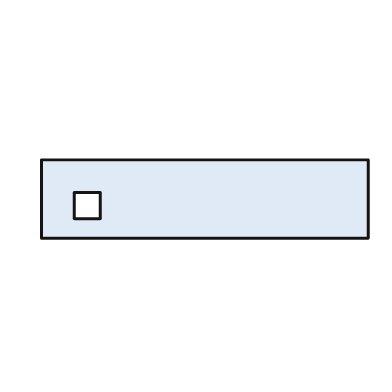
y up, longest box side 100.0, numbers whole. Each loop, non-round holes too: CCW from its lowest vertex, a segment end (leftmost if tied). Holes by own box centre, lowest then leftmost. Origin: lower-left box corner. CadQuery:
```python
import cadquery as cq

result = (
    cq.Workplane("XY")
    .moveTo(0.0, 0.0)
    .lineTo(100.0, 0.0)
    .lineTo(100.0, 24.0)
    .lineTo(0.0, 24.0)
    .close()
    .moveTo(10.0, 6.0)
    .lineTo(18.0, 6.0)
    .lineTo(18.0, 14.0)
    .lineTo(10.0, 14.0)
    .close()
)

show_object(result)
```